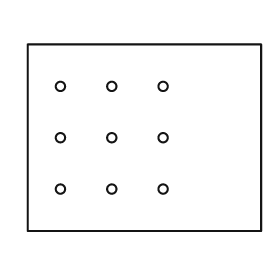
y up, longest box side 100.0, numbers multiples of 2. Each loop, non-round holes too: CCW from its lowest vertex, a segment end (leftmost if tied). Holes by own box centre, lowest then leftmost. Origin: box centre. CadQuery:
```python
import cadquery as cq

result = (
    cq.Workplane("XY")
    .moveTo(-50.0, -40.0)
    .lineTo(50.0, -40.0)
    .lineTo(50.0, 40.0)
    .lineTo(-50.0, 40.0)
    .close()
    .moveTo(-36.0, -22.0)
    .circle(2.0)
    .moveTo(-14.0, -22.0)
    .circle(2.0)
    .moveTo(8.0, -22.0)
    .circle(2.0)
    .moveTo(-36.0, 0.0)
    .circle(2.0)
    .moveTo(-14.0, 0.0)
    .circle(2.0)
    .moveTo(8.0, 0.0)
    .circle(2.0)
    .moveTo(-36.0, 22.0)
    .circle(2.0)
    .moveTo(-14.0, 22.0)
    .circle(2.0)
    .moveTo(8.0, 22.0)
    .circle(2.0)
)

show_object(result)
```